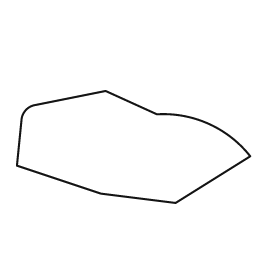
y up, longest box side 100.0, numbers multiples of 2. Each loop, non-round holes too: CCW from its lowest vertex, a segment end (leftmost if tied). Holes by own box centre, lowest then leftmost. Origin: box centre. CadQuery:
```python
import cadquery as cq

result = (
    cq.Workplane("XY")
    .moveTo(18.0, -24.0)
    .lineTo(50.0, -4.0)
    .threePointArc((32.0, 10.0), (10.0, 14.0))
    .lineTo(-12.0, 24.0)
    .lineTo(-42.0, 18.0)
    .threePointArc((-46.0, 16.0), (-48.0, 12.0))
    .lineTo(-50.0, -8.0)
    .lineTo(-14.0, -20.0)
    .close()
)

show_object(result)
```